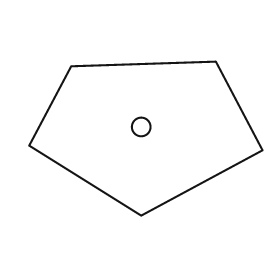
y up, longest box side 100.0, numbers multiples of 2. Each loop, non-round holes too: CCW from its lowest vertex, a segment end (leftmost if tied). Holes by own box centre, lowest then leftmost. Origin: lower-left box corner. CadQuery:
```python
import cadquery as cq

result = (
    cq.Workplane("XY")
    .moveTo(48.0, 0.0)
    .lineTo(100.0, 28.0)
    .lineTo(80.0, 66.0)
    .lineTo(18.0, 64.0)
    .lineTo(0.0, 30.0)
    .close()
    .moveTo(48.0, 38.0)
    .circle(4.0)
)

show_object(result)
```